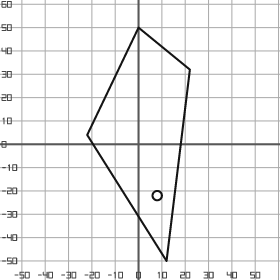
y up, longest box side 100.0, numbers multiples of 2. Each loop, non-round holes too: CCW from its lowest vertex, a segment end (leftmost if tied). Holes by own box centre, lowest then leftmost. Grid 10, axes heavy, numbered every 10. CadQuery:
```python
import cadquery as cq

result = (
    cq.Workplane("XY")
    .moveTo(12.0, -50.0)
    .lineTo(22.0, 32.0)
    .lineTo(0.0, 50.0)
    .lineTo(-22.0, 4.0)
    .close()
    .moveTo(8.0, -22.0)
    .circle(2.0)
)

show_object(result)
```